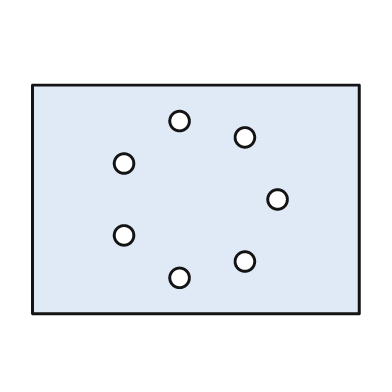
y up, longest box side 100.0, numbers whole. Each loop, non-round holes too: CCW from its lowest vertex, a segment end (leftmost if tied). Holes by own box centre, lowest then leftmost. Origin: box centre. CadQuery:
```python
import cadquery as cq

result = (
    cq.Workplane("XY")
    .moveTo(-50.0, -35.0)
    .lineTo(50.0, -35.0)
    .lineTo(50.0, 35.0)
    .lineTo(-50.0, 35.0)
    .close()
    .moveTo(-5.0, -24.0)
    .circle(3.0)
    .moveTo(15.0, -19.0)
    .circle(3.0)
    .moveTo(-22.0, -11.0)
    .circle(3.0)
    .moveTo(25.0, 0.0)
    .circle(3.0)
    .moveTo(-22.0, 11.0)
    .circle(3.0)
    .moveTo(15.0, 19.0)
    .circle(3.0)
    .moveTo(-5.0, 24.0)
    .circle(3.0)
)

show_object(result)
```